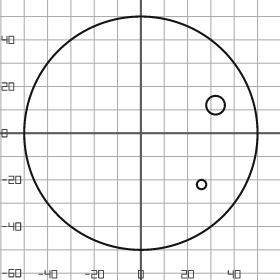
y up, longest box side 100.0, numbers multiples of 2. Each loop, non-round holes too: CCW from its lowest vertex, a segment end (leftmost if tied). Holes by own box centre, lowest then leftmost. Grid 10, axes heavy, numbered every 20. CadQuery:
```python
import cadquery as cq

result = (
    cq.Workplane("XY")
    .moveTo(0.0, 0.0)
    .circle(50.0)
    .moveTo(26.0, -22.0)
    .circle(2.0)
    .moveTo(32.0, 12.0)
    .circle(4.0)
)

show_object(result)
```